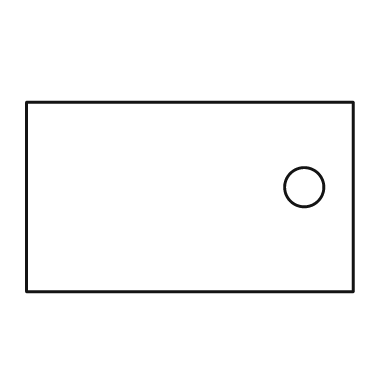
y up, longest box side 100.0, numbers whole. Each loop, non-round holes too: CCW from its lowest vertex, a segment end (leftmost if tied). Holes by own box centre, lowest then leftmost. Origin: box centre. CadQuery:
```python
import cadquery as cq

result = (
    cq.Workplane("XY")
    .moveTo(-50.0, -29.0)
    .lineTo(50.0, -29.0)
    .lineTo(50.0, 29.0)
    .lineTo(-50.0, 29.0)
    .close()
    .moveTo(35.0, 3.0)
    .circle(6.0)
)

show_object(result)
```